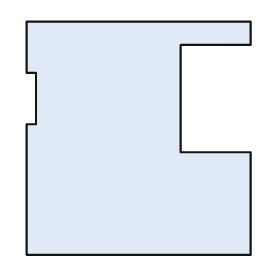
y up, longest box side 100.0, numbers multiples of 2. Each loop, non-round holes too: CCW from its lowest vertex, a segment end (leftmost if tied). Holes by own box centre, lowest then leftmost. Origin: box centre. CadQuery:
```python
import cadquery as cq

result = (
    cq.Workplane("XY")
    .moveTo(-48.0, -50.0)
    .lineTo(48.0, -50.0)
    .lineTo(48.0, -6.0)
    .lineTo(18.0, -6.0)
    .lineTo(18.0, 40.0)
    .lineTo(48.0, 40.0)
    .lineTo(48.0, 50.0)
    .lineTo(-48.0, 50.0)
    .lineTo(-48.0, 28.0)
    .lineTo(-44.0, 28.0)
    .lineTo(-44.0, 6.0)
    .lineTo(-48.0, 6.0)
    .close()
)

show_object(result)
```